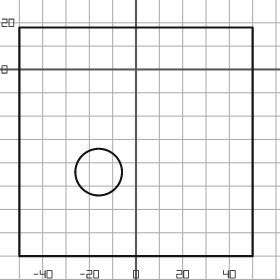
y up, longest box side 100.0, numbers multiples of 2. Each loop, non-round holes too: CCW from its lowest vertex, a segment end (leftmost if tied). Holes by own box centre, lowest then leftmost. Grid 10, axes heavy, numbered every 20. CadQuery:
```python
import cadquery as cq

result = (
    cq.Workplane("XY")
    .moveTo(-50.0, -80.0)
    .lineTo(50.0, -80.0)
    .lineTo(50.0, 18.0)
    .lineTo(-50.0, 18.0)
    .close()
    .moveTo(-16.0, -44.0)
    .circle(10.0)
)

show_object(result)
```